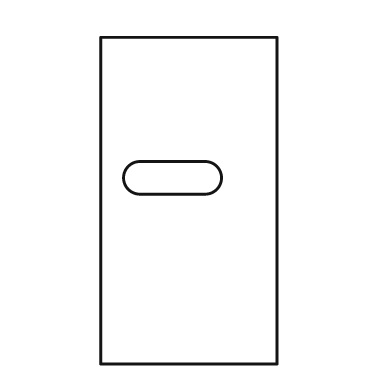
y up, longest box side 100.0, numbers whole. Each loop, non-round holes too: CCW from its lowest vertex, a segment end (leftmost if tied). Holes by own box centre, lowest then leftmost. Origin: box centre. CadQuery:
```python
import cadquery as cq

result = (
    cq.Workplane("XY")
    .moveTo(-27.0, -50.0)
    .lineTo(27.0, -50.0)
    .lineTo(27.0, 50.0)
    .lineTo(-27.0, 50.0)
    .close()
    .moveTo(-15.0, 2.0)
    .lineTo(5.0, 2.0)
    .threePointArc((10.0, 7.0), (5.0, 12.0))
    .lineTo(-15.0, 12.0)
    .threePointArc((-20.0, 7.0), (-15.0, 2.0))
    .close()
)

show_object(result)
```